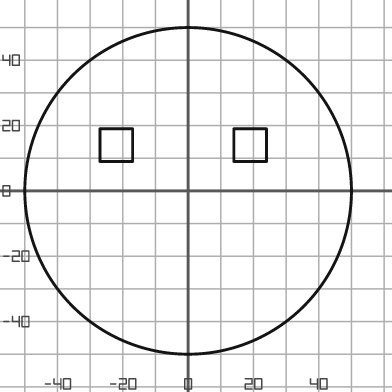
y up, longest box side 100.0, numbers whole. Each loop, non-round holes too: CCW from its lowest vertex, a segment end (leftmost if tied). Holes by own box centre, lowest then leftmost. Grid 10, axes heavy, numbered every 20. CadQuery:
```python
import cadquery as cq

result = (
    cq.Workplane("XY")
    .moveTo(0.0, 0.0)
    .circle(50.0)
    .moveTo(-27.0, 9.0)
    .lineTo(-17.0, 9.0)
    .lineTo(-17.0, 19.0)
    .lineTo(-27.0, 19.0)
    .close()
    .moveTo(14.0, 9.0)
    .lineTo(24.0, 9.0)
    .lineTo(24.0, 19.0)
    .lineTo(14.0, 19.0)
    .close()
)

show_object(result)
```